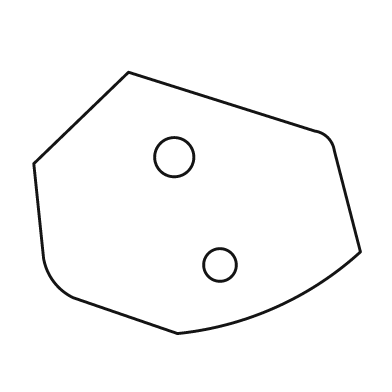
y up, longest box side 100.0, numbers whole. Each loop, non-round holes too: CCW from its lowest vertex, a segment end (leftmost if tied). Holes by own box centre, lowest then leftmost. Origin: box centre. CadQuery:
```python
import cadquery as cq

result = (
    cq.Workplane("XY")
    .moveTo(-6.0, -40.0)
    .threePointArc((24.0, -32.0), (50.0, -15.0))
    .lineTo(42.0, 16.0)
    .threePointArc((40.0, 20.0), (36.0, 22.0))
    .lineTo(-21.0, 40.0)
    .lineTo(-50.0, 12.0)
    .lineTo(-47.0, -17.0)
    .threePointArc((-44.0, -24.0), (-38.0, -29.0))
    .close()
    .moveTo(7.0, -19.0)
    .circle(5.0)
    .moveTo(-7.0, 14.0)
    .circle(6.0)
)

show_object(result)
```